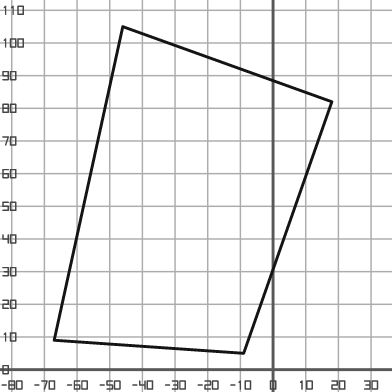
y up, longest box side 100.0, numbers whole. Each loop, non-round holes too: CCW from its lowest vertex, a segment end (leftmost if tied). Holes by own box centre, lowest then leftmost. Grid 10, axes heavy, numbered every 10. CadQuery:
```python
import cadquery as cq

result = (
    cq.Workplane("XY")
    .moveTo(-9.0, 5.0)
    .lineTo(18.0, 82.0)
    .lineTo(-46.0, 105.0)
    .lineTo(-67.0, 9.0)
    .close()
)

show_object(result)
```